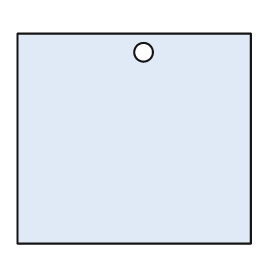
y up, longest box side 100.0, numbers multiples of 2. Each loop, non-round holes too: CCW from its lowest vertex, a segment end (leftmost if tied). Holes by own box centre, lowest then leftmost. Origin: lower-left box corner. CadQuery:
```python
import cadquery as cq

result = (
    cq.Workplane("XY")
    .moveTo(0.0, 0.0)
    .lineTo(100.0, 0.0)
    .lineTo(100.0, 90.0)
    .lineTo(0.0, 90.0)
    .close()
    .moveTo(54.0, 82.0)
    .circle(4.0)
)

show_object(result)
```